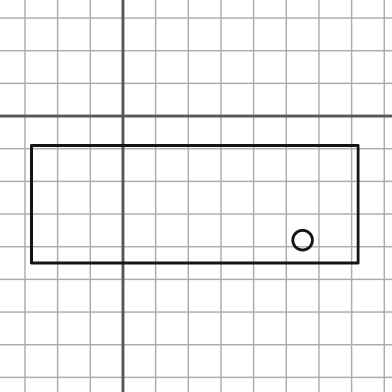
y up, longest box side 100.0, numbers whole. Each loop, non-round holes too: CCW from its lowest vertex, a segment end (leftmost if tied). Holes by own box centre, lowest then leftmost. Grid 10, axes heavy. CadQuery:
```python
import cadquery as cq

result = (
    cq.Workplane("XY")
    .moveTo(-28.0, -45.0)
    .lineTo(72.0, -45.0)
    .lineTo(72.0, -9.0)
    .lineTo(-28.0, -9.0)
    .close()
    .moveTo(55.0, -38.0)
    .circle(3.0)
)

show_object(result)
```